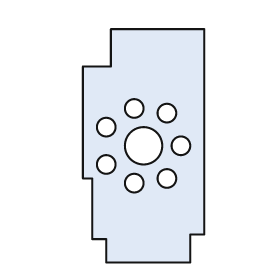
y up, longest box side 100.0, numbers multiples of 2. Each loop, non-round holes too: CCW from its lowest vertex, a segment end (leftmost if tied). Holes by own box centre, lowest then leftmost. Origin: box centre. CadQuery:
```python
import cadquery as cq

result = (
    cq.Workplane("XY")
    .moveTo(-16.0, -50.0)
    .lineTo(20.0, -50.0)
    .lineTo(20.0, -38.0)
    .lineTo(26.0, -38.0)
    .lineTo(26.0, 50.0)
    .lineTo(-14.0, 50.0)
    .lineTo(-14.0, 34.0)
    .lineTo(-26.0, 34.0)
    .lineTo(-26.0, -14.0)
    .lineTo(-22.0, -14.0)
    .lineTo(-22.0, -40.0)
    .lineTo(-16.0, -40.0)
    .close()
    .moveTo(-4.0, -16.0)
    .circle(4.0)
    .moveTo(10.0, -14.0)
    .circle(4.0)
    .moveTo(-16.0, -8.0)
    .circle(4.0)
    .moveTo(0.0, 0.0)
    .circle(8.0)
    .moveTo(16.0, 0.0)
    .circle(4.0)
    .moveTo(-16.0, 8.0)
    .circle(4.0)
    .moveTo(10.0, 14.0)
    .circle(4.0)
    .moveTo(-4.0, 16.0)
    .circle(4.0)
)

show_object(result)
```